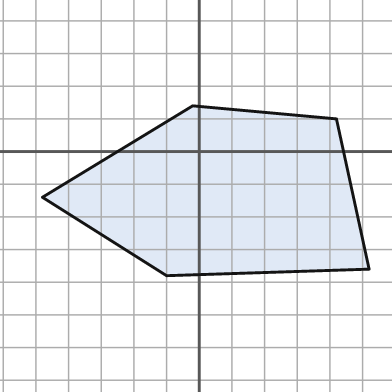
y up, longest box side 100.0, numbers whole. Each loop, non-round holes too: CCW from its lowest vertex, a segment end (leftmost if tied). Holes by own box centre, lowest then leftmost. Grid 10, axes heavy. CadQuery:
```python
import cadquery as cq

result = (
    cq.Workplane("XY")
    .moveTo(-10.0, -38.0)
    .lineTo(52.0, -36.0)
    .lineTo(42.0, 10.0)
    .lineTo(-2.0, 14.0)
    .lineTo(-48.0, -14.0)
    .close()
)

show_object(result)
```